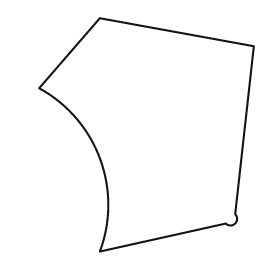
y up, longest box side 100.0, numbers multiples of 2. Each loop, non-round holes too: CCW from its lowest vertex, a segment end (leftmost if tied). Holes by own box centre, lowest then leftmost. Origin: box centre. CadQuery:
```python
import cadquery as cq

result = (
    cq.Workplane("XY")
    .moveTo(-20.0, -50.0)
    .lineTo(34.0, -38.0)
    .threePointArc((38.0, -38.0), (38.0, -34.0))
    .lineTo(46.0, 38.0)
    .lineTo(-20.0, 50.0)
    .lineTo(-46.0, 20.0)
    .threePointArc((-20.0, -10.0), (-20.0, -50.0))
    .close()
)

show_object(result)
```